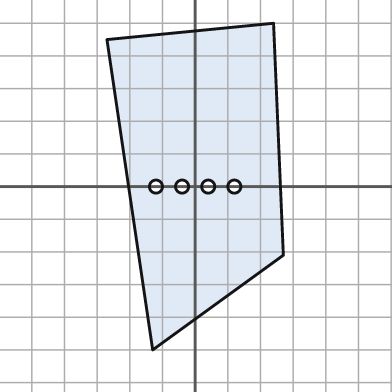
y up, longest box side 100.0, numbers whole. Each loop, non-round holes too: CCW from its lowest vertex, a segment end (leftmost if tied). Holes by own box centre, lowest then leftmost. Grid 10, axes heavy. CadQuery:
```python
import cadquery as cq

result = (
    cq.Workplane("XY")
    .moveTo(-13.0, -50.0)
    .lineTo(27.0, -21.0)
    .lineTo(24.0, 50.0)
    .lineTo(-27.0, 45.0)
    .close()
    .moveTo(-12.0, 0.0)
    .circle(2.0)
    .moveTo(-4.0, 0.0)
    .circle(2.0)
    .moveTo(4.0, 0.0)
    .circle(2.0)
    .moveTo(12.0, 0.0)
    .circle(2.0)
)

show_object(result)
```